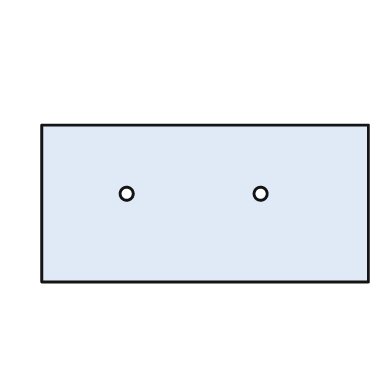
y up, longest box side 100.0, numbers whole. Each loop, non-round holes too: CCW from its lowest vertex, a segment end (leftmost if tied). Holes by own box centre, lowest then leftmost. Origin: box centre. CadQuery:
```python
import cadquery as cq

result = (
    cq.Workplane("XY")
    .moveTo(-50.0, -24.0)
    .lineTo(50.0, -24.0)
    .lineTo(50.0, 24.0)
    .lineTo(-50.0, 24.0)
    .close()
    .moveTo(-24.0, 3.0)
    .circle(2.0)
    .moveTo(17.0, 3.0)
    .circle(2.0)
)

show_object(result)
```